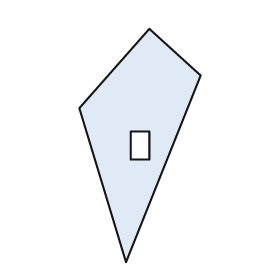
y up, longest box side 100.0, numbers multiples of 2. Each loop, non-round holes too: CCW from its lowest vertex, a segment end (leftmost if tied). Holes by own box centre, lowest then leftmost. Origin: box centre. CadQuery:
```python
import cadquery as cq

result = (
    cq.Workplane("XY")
    .moveTo(-6.0, -50.0)
    .lineTo(26.0, 30.0)
    .lineTo(4.0, 50.0)
    .lineTo(-26.0, 16.0)
    .close()
    .moveTo(-4.0, -6.0)
    .lineTo(4.0, -6.0)
    .lineTo(4.0, 6.0)
    .lineTo(-4.0, 6.0)
    .close()
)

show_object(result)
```